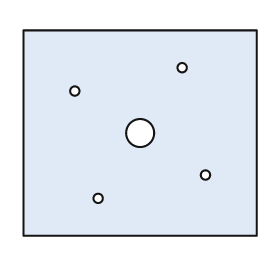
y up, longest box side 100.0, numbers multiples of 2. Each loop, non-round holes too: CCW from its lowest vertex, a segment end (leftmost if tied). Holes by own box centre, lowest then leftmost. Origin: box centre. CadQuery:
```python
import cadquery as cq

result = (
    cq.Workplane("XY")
    .moveTo(-50.0, -44.0)
    .lineTo(50.0, -44.0)
    .lineTo(50.0, 44.0)
    .lineTo(-50.0, 44.0)
    .close()
    .moveTo(-18.0, -28.0)
    .circle(2.0)
    .moveTo(28.0, -18.0)
    .circle(2.0)
    .moveTo(0.0, 0.0)
    .circle(6.0)
    .moveTo(-28.0, 18.0)
    .circle(2.0)
    .moveTo(18.0, 28.0)
    .circle(2.0)
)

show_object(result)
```